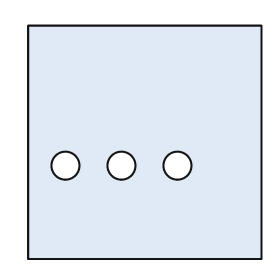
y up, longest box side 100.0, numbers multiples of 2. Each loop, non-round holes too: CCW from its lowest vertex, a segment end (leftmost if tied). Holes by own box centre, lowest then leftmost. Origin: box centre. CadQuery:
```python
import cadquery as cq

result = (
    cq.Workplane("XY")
    .moveTo(-50.0, -50.0)
    .lineTo(50.0, -50.0)
    .lineTo(50.0, 50.0)
    .lineTo(-50.0, 50.0)
    .close()
    .moveTo(-34.0, -10.0)
    .circle(6.0)
    .moveTo(-10.0, -10.0)
    .circle(6.0)
    .moveTo(14.0, -10.0)
    .circle(6.0)
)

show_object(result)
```